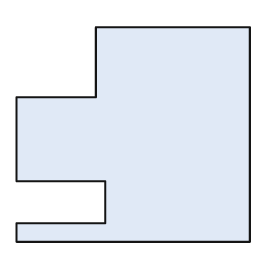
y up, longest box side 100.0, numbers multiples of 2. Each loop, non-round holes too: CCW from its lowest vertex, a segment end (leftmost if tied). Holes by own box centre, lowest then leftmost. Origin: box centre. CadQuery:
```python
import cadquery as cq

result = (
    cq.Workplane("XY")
    .moveTo(-50.0, -46.0)
    .lineTo(50.0, -46.0)
    .lineTo(50.0, 46.0)
    .lineTo(-16.0, 46.0)
    .lineTo(-16.0, 16.0)
    .lineTo(-50.0, 16.0)
    .lineTo(-50.0, -20.0)
    .lineTo(-12.0, -20.0)
    .lineTo(-12.0, -38.0)
    .lineTo(-50.0, -38.0)
    .close()
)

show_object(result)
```